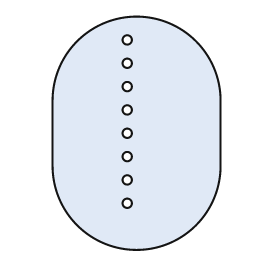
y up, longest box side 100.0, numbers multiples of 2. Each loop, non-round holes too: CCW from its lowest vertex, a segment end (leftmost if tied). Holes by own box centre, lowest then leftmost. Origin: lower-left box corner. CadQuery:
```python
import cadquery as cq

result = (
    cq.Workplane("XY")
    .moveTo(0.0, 36.0)
    .threePointArc((36.0, 0.0), (72.0, 36.0))
    .lineTo(72.0, 64.0)
    .threePointArc((36.0, 100.0), (0.0, 64.0))
    .close()
    .moveTo(32.0, 20.0)
    .circle(2.0)
    .moveTo(32.0, 30.0)
    .circle(2.0)
    .moveTo(32.0, 40.0)
    .circle(2.0)
    .moveTo(32.0, 50.0)
    .circle(2.0)
    .moveTo(32.0, 60.0)
    .circle(2.0)
    .moveTo(32.0, 70.0)
    .circle(2.0)
    .moveTo(32.0, 80.0)
    .circle(2.0)
    .moveTo(32.0, 90.0)
    .circle(2.0)
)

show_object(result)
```